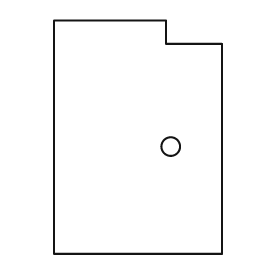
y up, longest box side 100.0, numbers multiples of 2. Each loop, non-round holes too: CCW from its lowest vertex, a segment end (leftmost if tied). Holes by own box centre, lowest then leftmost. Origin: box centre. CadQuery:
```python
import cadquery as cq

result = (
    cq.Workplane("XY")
    .moveTo(-36.0, -50.0)
    .lineTo(36.0, -50.0)
    .lineTo(36.0, 40.0)
    .lineTo(12.0, 40.0)
    .lineTo(12.0, 50.0)
    .lineTo(-36.0, 50.0)
    .close()
    .moveTo(14.0, -4.0)
    .circle(4.0)
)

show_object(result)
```